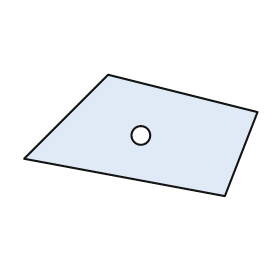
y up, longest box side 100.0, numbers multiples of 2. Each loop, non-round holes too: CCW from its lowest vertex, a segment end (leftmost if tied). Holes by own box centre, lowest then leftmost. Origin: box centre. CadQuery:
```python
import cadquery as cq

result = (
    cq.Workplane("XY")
    .moveTo(36.0, -26.0)
    .lineTo(50.0, 10.0)
    .lineTo(-14.0, 26.0)
    .lineTo(-50.0, -10.0)
    .close()
    .moveTo(0.0, 0.0)
    .circle(4.0)
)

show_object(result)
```